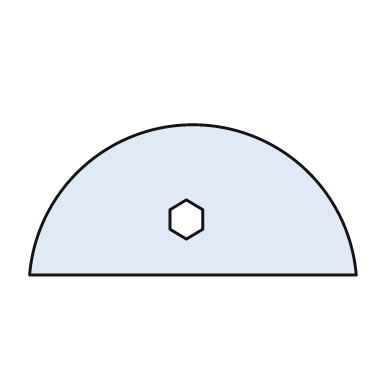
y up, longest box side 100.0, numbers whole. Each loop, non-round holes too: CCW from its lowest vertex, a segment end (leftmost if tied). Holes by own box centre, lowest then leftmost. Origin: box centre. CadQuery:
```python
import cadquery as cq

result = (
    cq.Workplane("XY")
    .moveTo(-50.0, -23.0)
    .lineTo(50.0, -23.0)
    .threePointArc((0.0, 23.0), (-50.0, -23.0))
    .close()
    .moveTo(-2.0, -12.0)
    .lineTo(3.0, -9.0)
    .lineTo(3.0, -3.0)
    .lineTo(-2.0, 0.0)
    .lineTo(-7.0, -3.0)
    .lineTo(-7.0, -9.0)
    .close()
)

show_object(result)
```